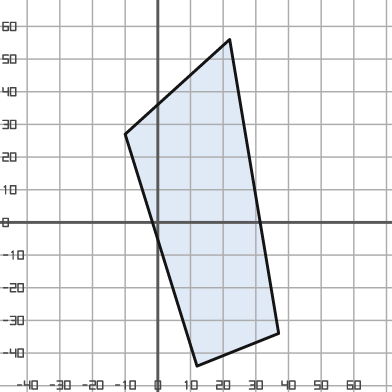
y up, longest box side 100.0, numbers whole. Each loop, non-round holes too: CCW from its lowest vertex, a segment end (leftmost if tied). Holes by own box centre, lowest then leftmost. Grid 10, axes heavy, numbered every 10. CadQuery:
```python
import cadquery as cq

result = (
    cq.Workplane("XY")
    .moveTo(12.0, -44.0)
    .lineTo(37.0, -34.0)
    .lineTo(22.0, 56.0)
    .lineTo(-10.0, 27.0)
    .close()
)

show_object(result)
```